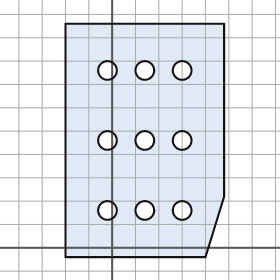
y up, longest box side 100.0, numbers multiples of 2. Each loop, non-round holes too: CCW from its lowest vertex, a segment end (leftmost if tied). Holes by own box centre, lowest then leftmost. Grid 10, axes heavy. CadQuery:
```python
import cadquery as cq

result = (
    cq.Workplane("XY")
    .moveTo(-20.0, -4.0)
    .lineTo(40.0, -4.0)
    .lineTo(48.0, 22.0)
    .lineTo(48.0, 96.0)
    .lineTo(-20.0, 96.0)
    .close()
    .moveTo(-2.0, 16.0)
    .circle(4.0)
    .moveTo(14.0, 16.0)
    .circle(4.0)
    .moveTo(30.0, 16.0)
    .circle(4.0)
    .moveTo(-2.0, 46.0)
    .circle(4.0)
    .moveTo(14.0, 46.0)
    .circle(4.0)
    .moveTo(30.0, 46.0)
    .circle(4.0)
    .moveTo(-2.0, 76.0)
    .circle(4.0)
    .moveTo(14.0, 76.0)
    .circle(4.0)
    .moveTo(30.0, 76.0)
    .circle(4.0)
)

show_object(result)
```